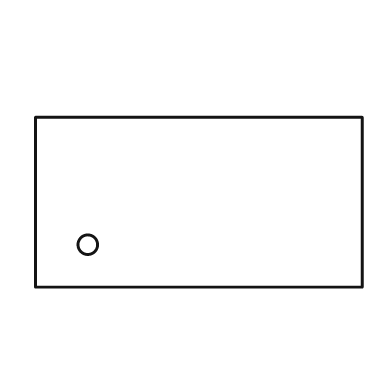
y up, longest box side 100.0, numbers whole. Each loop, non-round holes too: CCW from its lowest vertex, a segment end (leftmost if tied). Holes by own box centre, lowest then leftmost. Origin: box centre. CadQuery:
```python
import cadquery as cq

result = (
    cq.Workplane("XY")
    .moveTo(-50.0, -26.0)
    .lineTo(50.0, -26.0)
    .lineTo(50.0, 26.0)
    .lineTo(-50.0, 26.0)
    .close()
    .moveTo(-34.0, -13.0)
    .circle(3.0)
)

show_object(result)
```